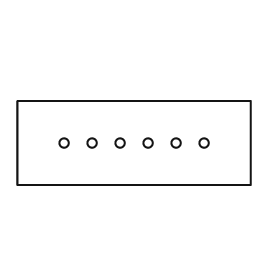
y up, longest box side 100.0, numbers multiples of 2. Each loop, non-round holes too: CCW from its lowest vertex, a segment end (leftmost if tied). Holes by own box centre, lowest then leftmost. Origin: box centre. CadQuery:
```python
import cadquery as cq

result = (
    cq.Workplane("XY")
    .moveTo(-50.0, -18.0)
    .lineTo(50.0, -18.0)
    .lineTo(50.0, 18.0)
    .lineTo(-50.0, 18.0)
    .close()
    .moveTo(-30.0, 0.0)
    .circle(2.0)
    .moveTo(-18.0, 0.0)
    .circle(2.0)
    .moveTo(-6.0, 0.0)
    .circle(2.0)
    .moveTo(6.0, 0.0)
    .circle(2.0)
    .moveTo(18.0, 0.0)
    .circle(2.0)
    .moveTo(30.0, 0.0)
    .circle(2.0)
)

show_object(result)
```